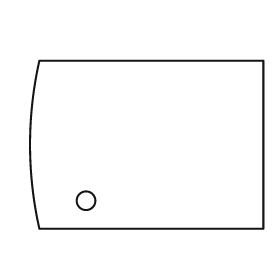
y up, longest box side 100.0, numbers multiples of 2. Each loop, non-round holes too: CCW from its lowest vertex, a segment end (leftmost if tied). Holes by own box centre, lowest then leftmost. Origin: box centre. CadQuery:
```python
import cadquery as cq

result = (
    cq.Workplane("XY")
    .moveTo(-46.0, -36.0)
    .lineTo(50.0, -36.0)
    .lineTo(50.0, 36.0)
    .lineTo(-46.0, 36.0)
    .threePointArc((-50.0, 0.0), (-46.0, -36.0))
    .close()
    .moveTo(-26.0, -24.0)
    .circle(4.0)
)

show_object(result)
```